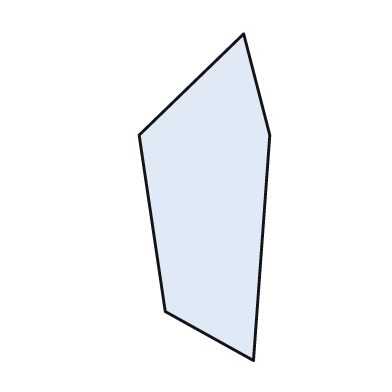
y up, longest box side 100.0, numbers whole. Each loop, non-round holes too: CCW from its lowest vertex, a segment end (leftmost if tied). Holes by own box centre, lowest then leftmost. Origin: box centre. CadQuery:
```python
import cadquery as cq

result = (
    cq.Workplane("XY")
    .moveTo(15.0, -50.0)
    .lineTo(20.0, 19.0)
    .lineTo(12.0, 50.0)
    .lineTo(-20.0, 19.0)
    .lineTo(-12.0, -35.0)
    .close()
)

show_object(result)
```